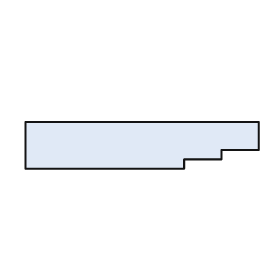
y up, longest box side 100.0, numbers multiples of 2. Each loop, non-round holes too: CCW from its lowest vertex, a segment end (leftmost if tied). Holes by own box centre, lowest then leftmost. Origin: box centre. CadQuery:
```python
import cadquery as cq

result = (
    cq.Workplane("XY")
    .moveTo(-50.0, -10.0)
    .lineTo(18.0, -10.0)
    .lineTo(18.0, -6.0)
    .lineTo(34.0, -6.0)
    .lineTo(34.0, -2.0)
    .lineTo(50.0, -2.0)
    .lineTo(50.0, 10.0)
    .lineTo(-50.0, 10.0)
    .close()
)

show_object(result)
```